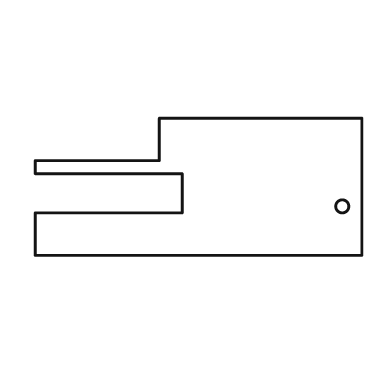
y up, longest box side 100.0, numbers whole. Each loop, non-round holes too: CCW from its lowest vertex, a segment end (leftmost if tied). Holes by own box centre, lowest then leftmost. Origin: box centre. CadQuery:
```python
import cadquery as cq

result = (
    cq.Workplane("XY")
    .moveTo(-50.0, -21.0)
    .lineTo(50.0, -21.0)
    .lineTo(50.0, 21.0)
    .lineTo(-12.0, 21.0)
    .lineTo(-12.0, 8.0)
    .lineTo(-50.0, 8.0)
    .lineTo(-50.0, 4.0)
    .lineTo(-5.0, 4.0)
    .lineTo(-5.0, -8.0)
    .lineTo(-50.0, -8.0)
    .close()
    .moveTo(44.0, -6.0)
    .circle(2.0)
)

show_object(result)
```